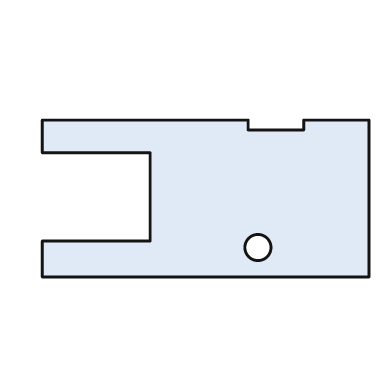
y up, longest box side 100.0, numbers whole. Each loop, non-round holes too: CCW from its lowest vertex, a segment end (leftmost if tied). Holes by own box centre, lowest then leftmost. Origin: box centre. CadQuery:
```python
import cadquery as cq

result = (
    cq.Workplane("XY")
    .moveTo(-50.0, -24.0)
    .lineTo(50.0, -24.0)
    .lineTo(50.0, 24.0)
    .lineTo(30.0, 24.0)
    .lineTo(30.0, 21.0)
    .lineTo(13.0, 21.0)
    .lineTo(13.0, 24.0)
    .lineTo(-50.0, 24.0)
    .lineTo(-50.0, 14.0)
    .lineTo(-17.0, 14.0)
    .lineTo(-17.0, -13.0)
    .lineTo(-50.0, -13.0)
    .close()
    .moveTo(16.0, -15.0)
    .circle(4.0)
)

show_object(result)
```